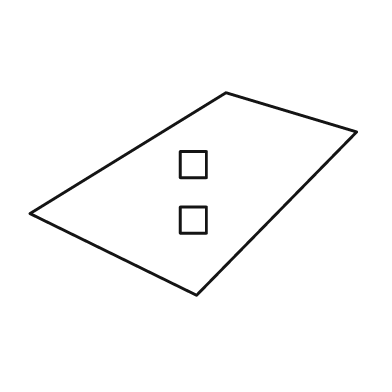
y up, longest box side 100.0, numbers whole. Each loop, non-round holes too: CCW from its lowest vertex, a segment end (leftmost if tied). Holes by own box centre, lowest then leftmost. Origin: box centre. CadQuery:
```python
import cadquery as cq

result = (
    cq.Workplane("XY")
    .moveTo(1.0, -31.0)
    .lineTo(50.0, 19.0)
    .lineTo(10.0, 31.0)
    .lineTo(-50.0, -6.0)
    .close()
    .moveTo(-4.0, -12.0)
    .lineTo(4.0, -12.0)
    .lineTo(4.0, -4.0)
    .lineTo(-4.0, -4.0)
    .close()
    .moveTo(-4.0, 5.0)
    .lineTo(4.0, 5.0)
    .lineTo(4.0, 13.0)
    .lineTo(-4.0, 13.0)
    .close()
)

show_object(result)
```